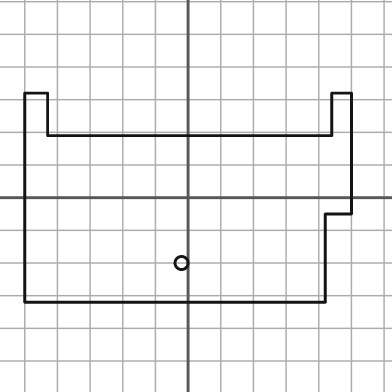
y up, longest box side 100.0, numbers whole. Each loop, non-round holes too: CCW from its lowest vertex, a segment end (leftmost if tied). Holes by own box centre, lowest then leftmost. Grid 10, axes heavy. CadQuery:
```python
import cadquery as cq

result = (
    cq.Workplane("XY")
    .moveTo(-50.0, -32.0)
    .lineTo(42.0, -32.0)
    .lineTo(42.0, -5.0)
    .lineTo(50.0, -5.0)
    .lineTo(50.0, 32.0)
    .lineTo(44.0, 32.0)
    .lineTo(44.0, 19.0)
    .lineTo(-43.0, 19.0)
    .lineTo(-43.0, 32.0)
    .lineTo(-50.0, 32.0)
    .close()
    .moveTo(-2.0, -20.0)
    .circle(2.0)
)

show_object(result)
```